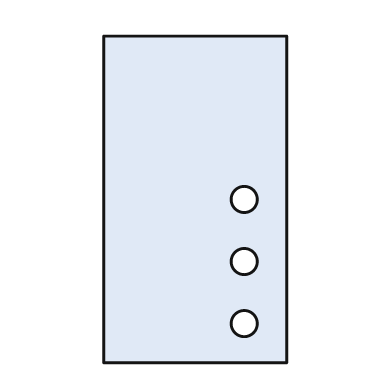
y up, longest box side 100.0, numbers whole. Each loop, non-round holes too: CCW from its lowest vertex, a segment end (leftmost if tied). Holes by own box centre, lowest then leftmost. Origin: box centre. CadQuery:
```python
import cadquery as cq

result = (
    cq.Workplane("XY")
    .moveTo(-28.0, -50.0)
    .lineTo(28.0, -50.0)
    .lineTo(28.0, 50.0)
    .lineTo(-28.0, 50.0)
    .close()
    .moveTo(15.0, -38.0)
    .circle(4.0)
    .moveTo(15.0, -19.0)
    .circle(4.0)
    .moveTo(15.0, 0.0)
    .circle(4.0)
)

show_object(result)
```